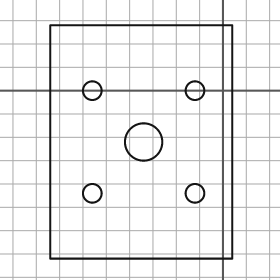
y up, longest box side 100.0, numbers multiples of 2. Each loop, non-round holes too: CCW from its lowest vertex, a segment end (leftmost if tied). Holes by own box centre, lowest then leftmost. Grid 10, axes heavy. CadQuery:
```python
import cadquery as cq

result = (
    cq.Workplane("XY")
    .moveTo(-74.0, -72.0)
    .lineTo(4.0, -72.0)
    .lineTo(4.0, 28.0)
    .lineTo(-74.0, 28.0)
    .close()
    .moveTo(-56.0, -44.0)
    .circle(4.0)
    .moveTo(-12.0, -44.0)
    .circle(4.0)
    .moveTo(-34.0, -22.0)
    .circle(8.0)
    .moveTo(-56.0, 0.0)
    .circle(4.0)
    .moveTo(-12.0, 0.0)
    .circle(4.0)
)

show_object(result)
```